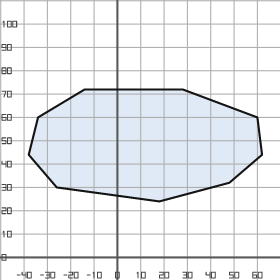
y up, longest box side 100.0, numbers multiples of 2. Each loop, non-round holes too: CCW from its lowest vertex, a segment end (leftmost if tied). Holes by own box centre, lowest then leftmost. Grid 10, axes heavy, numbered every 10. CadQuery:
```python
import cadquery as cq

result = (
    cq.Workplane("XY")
    .moveTo(18.0, 24.0)
    .lineTo(48.0, 32.0)
    .lineTo(62.0, 44.0)
    .lineTo(60.0, 60.0)
    .lineTo(28.0, 72.0)
    .lineTo(-14.0, 72.0)
    .lineTo(-34.0, 60.0)
    .lineTo(-38.0, 44.0)
    .lineTo(-26.0, 30.0)
    .close()
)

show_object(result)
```